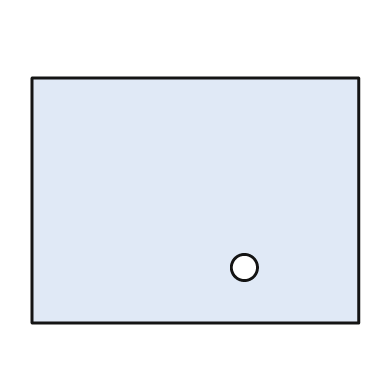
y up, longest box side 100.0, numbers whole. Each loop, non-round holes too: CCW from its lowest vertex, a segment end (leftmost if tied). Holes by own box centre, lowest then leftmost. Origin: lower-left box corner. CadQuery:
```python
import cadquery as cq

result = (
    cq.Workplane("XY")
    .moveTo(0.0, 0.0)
    .lineTo(100.0, 0.0)
    .lineTo(100.0, 75.0)
    .lineTo(0.0, 75.0)
    .close()
    .moveTo(65.0, 17.0)
    .circle(4.0)
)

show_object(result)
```